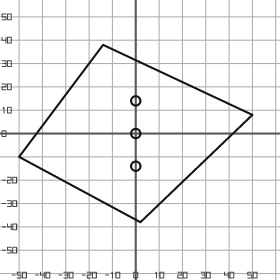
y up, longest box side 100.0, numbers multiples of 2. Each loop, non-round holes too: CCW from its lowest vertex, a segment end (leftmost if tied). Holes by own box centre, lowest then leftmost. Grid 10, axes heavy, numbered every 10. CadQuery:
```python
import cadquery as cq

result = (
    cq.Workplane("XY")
    .moveTo(2.0, -38.0)
    .lineTo(50.0, 8.0)
    .lineTo(-14.0, 38.0)
    .lineTo(-50.0, -10.0)
    .close()
    .moveTo(0.0, -14.0)
    .circle(2.0)
    .moveTo(0.0, 0.0)
    .circle(2.0)
    .moveTo(0.0, 14.0)
    .circle(2.0)
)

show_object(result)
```